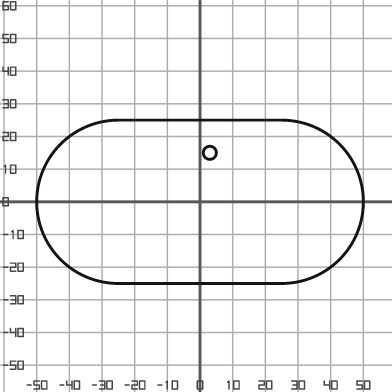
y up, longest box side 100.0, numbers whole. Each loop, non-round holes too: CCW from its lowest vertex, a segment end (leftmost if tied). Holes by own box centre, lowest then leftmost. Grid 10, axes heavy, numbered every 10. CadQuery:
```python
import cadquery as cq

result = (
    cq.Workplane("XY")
    .moveTo(-25.0, -25.0)
    .lineTo(25.0, -25.0)
    .threePointArc((50.0, 0.0), (25.0, 25.0))
    .lineTo(-25.0, 25.0)
    .threePointArc((-50.0, 0.0), (-25.0, -25.0))
    .close()
    .moveTo(3.0, 15.0)
    .circle(2.0)
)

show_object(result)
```